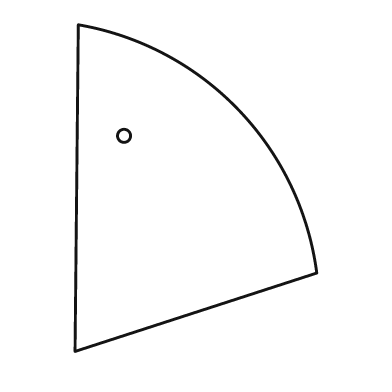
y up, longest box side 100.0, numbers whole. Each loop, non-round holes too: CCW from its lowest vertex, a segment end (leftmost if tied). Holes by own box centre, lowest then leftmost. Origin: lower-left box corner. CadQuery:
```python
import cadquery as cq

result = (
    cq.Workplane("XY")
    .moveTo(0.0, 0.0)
    .lineTo(74.0, 24.0)
    .threePointArc((50.0, 74.0), (1.0, 100.0))
    .close()
    .moveTo(15.0, 66.0)
    .circle(2.0)
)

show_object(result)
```